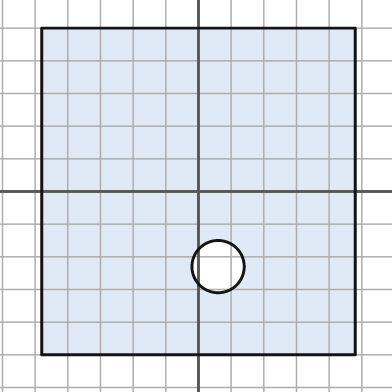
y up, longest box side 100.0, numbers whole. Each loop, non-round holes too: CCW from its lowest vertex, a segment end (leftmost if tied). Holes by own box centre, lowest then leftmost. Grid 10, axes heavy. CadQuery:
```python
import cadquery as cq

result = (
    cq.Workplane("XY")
    .moveTo(-48.0, -50.0)
    .lineTo(48.0, -50.0)
    .lineTo(48.0, 50.0)
    .lineTo(-48.0, 50.0)
    .close()
    .moveTo(6.0, -23.0)
    .circle(8.0)
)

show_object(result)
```